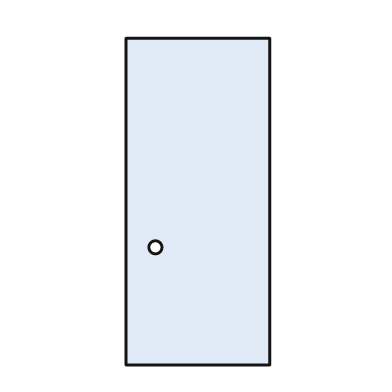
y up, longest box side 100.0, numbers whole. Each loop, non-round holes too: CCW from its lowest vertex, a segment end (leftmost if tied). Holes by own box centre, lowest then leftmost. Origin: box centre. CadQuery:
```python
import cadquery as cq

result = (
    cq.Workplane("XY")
    .moveTo(-22.0, -50.0)
    .lineTo(22.0, -50.0)
    .lineTo(22.0, 50.0)
    .lineTo(-22.0, 50.0)
    .close()
    .moveTo(-13.0, -14.0)
    .circle(2.0)
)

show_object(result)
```